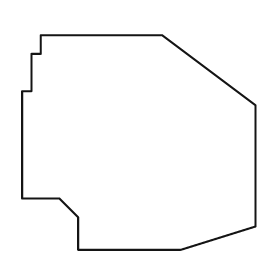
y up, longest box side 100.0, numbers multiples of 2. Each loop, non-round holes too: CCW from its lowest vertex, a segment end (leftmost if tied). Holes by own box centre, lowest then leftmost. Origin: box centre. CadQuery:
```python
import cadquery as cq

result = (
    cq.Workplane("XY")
    .moveTo(-26.0, -46.0)
    .lineTo(18.0, -46.0)
    .lineTo(50.0, -36.0)
    .lineTo(50.0, 16.0)
    .lineTo(10.0, 46.0)
    .lineTo(-42.0, 46.0)
    .lineTo(-42.0, 38.0)
    .lineTo(-46.0, 38.0)
    .lineTo(-46.0, 22.0)
    .lineTo(-50.0, 22.0)
    .lineTo(-50.0, -24.0)
    .lineTo(-34.0, -24.0)
    .lineTo(-26.0, -32.0)
    .close()
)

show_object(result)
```